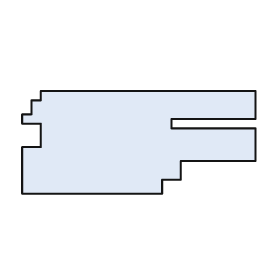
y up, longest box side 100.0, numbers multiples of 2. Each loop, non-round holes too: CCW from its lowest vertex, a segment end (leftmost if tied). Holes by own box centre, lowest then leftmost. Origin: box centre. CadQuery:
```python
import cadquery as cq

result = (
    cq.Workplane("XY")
    .moveTo(-50.0, -22.0)
    .lineTo(10.0, -22.0)
    .lineTo(10.0, -16.0)
    .lineTo(18.0, -16.0)
    .lineTo(18.0, -8.0)
    .lineTo(50.0, -8.0)
    .lineTo(50.0, 6.0)
    .lineTo(14.0, 6.0)
    .lineTo(14.0, 10.0)
    .lineTo(50.0, 10.0)
    .lineTo(50.0, 22.0)
    .lineTo(-42.0, 22.0)
    .lineTo(-42.0, 18.0)
    .lineTo(-46.0, 18.0)
    .lineTo(-46.0, 12.0)
    .lineTo(-50.0, 12.0)
    .lineTo(-50.0, 8.0)
    .lineTo(-42.0, 8.0)
    .lineTo(-42.0, -2.0)
    .lineTo(-50.0, -2.0)
    .close()
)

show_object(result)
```